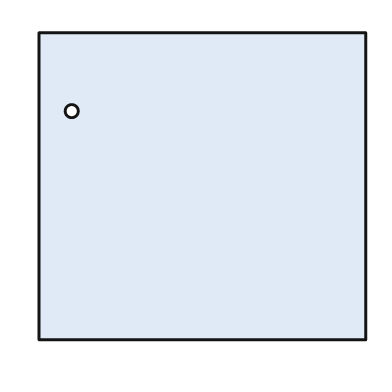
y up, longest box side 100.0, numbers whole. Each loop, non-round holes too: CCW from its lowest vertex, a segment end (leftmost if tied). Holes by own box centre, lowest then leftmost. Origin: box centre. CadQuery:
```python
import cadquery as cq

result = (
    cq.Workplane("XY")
    .moveTo(-50.0, -47.0)
    .lineTo(50.0, -47.0)
    .lineTo(50.0, 47.0)
    .lineTo(-50.0, 47.0)
    .close()
    .moveTo(-40.0, 23.0)
    .circle(2.0)
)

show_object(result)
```